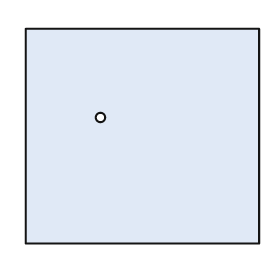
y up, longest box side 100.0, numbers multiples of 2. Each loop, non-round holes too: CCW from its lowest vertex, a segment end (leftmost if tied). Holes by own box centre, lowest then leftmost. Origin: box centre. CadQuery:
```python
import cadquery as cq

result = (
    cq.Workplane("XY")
    .moveTo(-50.0, -46.0)
    .lineTo(50.0, -46.0)
    .lineTo(50.0, 46.0)
    .lineTo(-50.0, 46.0)
    .close()
    .moveTo(-18.0, 8.0)
    .circle(2.0)
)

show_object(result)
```